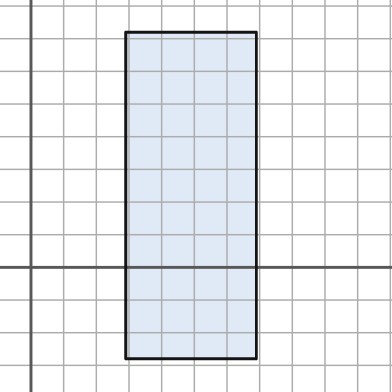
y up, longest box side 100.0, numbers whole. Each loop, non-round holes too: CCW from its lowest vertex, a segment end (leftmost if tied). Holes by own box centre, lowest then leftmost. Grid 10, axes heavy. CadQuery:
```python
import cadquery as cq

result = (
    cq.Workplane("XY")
    .moveTo(29.0, -28.0)
    .lineTo(69.0, -28.0)
    .lineTo(69.0, 72.0)
    .lineTo(29.0, 72.0)
    .close()
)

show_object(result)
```